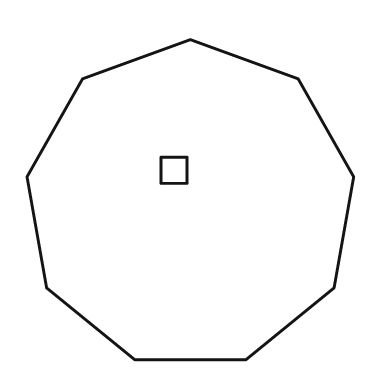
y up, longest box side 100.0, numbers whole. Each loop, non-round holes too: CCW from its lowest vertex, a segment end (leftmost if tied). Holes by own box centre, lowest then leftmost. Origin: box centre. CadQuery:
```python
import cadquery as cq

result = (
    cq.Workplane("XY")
    .moveTo(-17.0, -49.0)
    .lineTo(17.0, -49.0)
    .lineTo(44.0, -27.0)
    .lineTo(50.0, 7.0)
    .lineTo(33.0, 37.0)
    .lineTo(0.0, 49.0)
    .lineTo(-33.0, 37.0)
    .lineTo(-50.0, 7.0)
    .lineTo(-44.0, -27.0)
    .close()
    .moveTo(-9.0, 5.0)
    .lineTo(-1.0, 5.0)
    .lineTo(-1.0, 13.0)
    .lineTo(-9.0, 13.0)
    .close()
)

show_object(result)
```